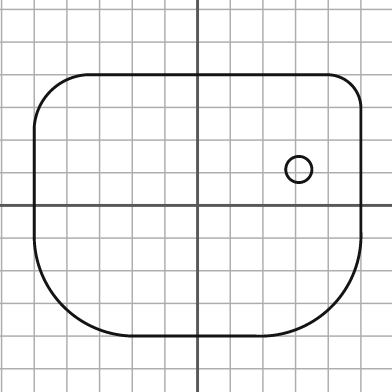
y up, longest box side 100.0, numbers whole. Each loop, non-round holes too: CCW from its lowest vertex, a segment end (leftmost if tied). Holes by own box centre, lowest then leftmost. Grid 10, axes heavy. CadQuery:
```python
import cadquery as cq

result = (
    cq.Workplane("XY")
    .moveTo(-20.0, -40.0)
    .lineTo(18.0, -40.0)
    .threePointArc((41.0, -31.0), (50.0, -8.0))
    .lineTo(50.0, 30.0)
    .threePointArc((47.0, 37.0), (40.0, 40.0))
    .lineTo(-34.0, 40.0)
    .threePointArc((-45.0, 35.0), (-50.0, 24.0))
    .lineTo(-50.0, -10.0)
    .threePointArc((-41.0, -31.0), (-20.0, -40.0))
    .close()
    .moveTo(31.0, 11.0)
    .circle(4.0)
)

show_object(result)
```